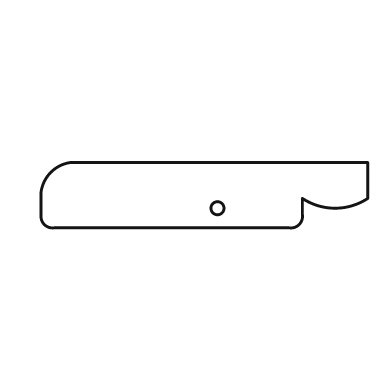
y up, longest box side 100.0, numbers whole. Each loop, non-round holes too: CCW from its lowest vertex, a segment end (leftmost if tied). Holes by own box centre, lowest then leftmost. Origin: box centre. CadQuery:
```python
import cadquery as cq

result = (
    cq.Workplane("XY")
    .moveTo(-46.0, -10.0)
    .lineTo(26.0, -10.0)
    .threePointArc((29.0, -9.0), (30.0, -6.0))
    .lineTo(30.0, -1.0)
    .threePointArc((40.0, -4.0), (50.0, -1.0))
    .lineTo(50.0, 10.0)
    .lineTo(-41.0, 10.0)
    .threePointArc((-47.0, 7.0), (-50.0, 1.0))
    .lineTo(-50.0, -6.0)
    .threePointArc((-49.0, -9.0), (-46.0, -10.0))
    .close()
    .moveTo(4.0, -4.0)
    .circle(2.0)
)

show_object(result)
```